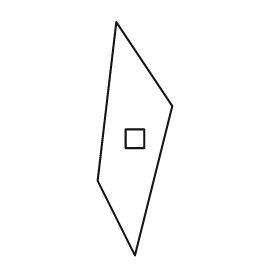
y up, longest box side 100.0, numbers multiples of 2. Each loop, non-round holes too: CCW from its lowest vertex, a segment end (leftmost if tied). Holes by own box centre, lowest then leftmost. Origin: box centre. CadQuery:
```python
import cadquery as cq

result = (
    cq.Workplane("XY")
    .moveTo(0.0, -50.0)
    .lineTo(16.0, 14.0)
    .lineTo(-8.0, 50.0)
    .lineTo(-16.0, -18.0)
    .close()
    .moveTo(-4.0, -4.0)
    .lineTo(4.0, -4.0)
    .lineTo(4.0, 4.0)
    .lineTo(-4.0, 4.0)
    .close()
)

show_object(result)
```